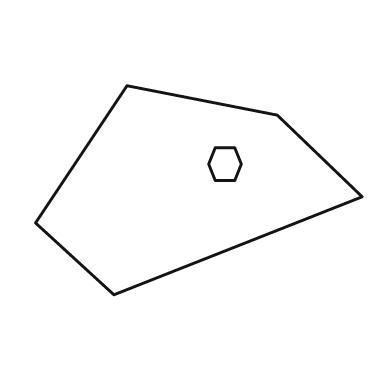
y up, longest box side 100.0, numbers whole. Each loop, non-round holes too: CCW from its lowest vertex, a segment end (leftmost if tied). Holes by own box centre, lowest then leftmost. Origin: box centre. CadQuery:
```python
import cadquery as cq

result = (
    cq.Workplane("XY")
    .moveTo(-26.0, -32.0)
    .lineTo(50.0, -2.0)
    .lineTo(24.0, 23.0)
    .lineTo(-22.0, 32.0)
    .lineTo(-50.0, -10.0)
    .close()
    .moveTo(5.0, 3.0)
    .lineTo(11.0, 3.0)
    .lineTo(13.0, 8.0)
    .lineTo(11.0, 13.0)
    .lineTo(5.0, 13.0)
    .lineTo(3.0, 8.0)
    .close()
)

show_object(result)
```